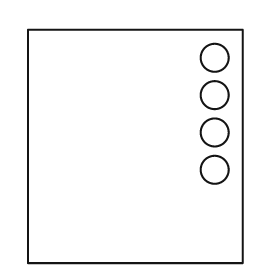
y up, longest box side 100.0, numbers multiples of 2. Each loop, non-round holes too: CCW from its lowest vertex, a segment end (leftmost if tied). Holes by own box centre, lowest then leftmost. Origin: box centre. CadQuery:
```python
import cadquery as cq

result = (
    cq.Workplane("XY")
    .moveTo(-46.0, -50.0)
    .lineTo(46.0, -50.0)
    .lineTo(46.0, 50.0)
    .lineTo(-46.0, 50.0)
    .close()
    .moveTo(34.0, -10.0)
    .circle(6.0)
    .moveTo(34.0, 6.0)
    .circle(6.0)
    .moveTo(34.0, 22.0)
    .circle(6.0)
    .moveTo(34.0, 38.0)
    .circle(6.0)
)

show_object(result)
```